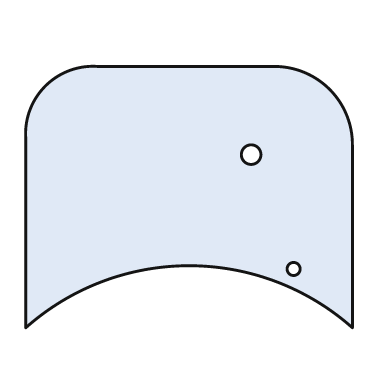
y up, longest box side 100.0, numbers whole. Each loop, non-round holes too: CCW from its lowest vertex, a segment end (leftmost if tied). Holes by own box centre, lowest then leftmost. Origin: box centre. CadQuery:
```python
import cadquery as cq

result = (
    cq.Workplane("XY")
    .moveTo(-50.0, -40.0)
    .threePointArc((0.0, -21.0), (50.0, -40.0))
    .lineTo(50.0, 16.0)
    .threePointArc((43.0, 33.0), (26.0, 40.0))
    .lineTo(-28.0, 40.0)
    .threePointArc((-44.0, 34.0), (-50.0, 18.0))
    .close()
    .moveTo(32.0, -22.0)
    .circle(2.0)
    .moveTo(19.0, 13.0)
    .circle(3.0)
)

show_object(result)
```